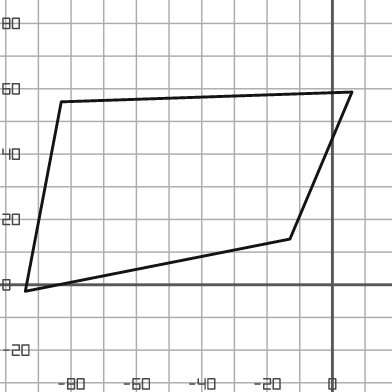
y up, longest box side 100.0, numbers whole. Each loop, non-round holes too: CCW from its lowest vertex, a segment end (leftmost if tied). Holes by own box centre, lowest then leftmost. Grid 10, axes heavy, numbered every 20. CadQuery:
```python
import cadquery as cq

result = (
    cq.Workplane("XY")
    .moveTo(-94.0, -2.0)
    .lineTo(-13.0, 14.0)
    .lineTo(6.0, 59.0)
    .lineTo(-83.0, 56.0)
    .close()
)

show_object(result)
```